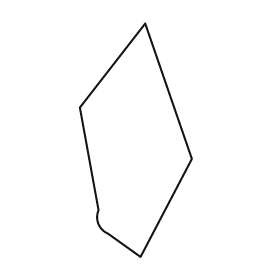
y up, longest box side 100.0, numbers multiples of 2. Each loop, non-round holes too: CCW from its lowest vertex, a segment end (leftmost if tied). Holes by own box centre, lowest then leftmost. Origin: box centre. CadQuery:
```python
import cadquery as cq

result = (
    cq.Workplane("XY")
    .moveTo(2.0, -50.0)
    .lineTo(24.0, -8.0)
    .lineTo(4.0, 50.0)
    .lineTo(-24.0, 14.0)
    .lineTo(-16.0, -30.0)
    .threePointArc((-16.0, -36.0), (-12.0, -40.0))
    .close()
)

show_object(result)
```